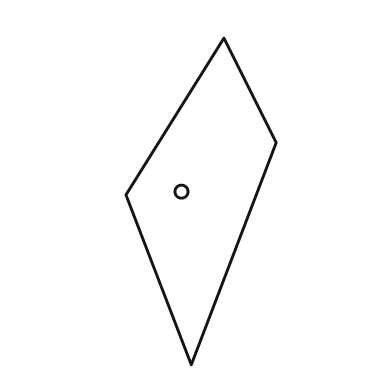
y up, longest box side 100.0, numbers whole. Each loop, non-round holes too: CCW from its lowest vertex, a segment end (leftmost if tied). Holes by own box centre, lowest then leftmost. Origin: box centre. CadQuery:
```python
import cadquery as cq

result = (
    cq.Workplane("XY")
    .moveTo(-3.0, -50.0)
    .lineTo(23.0, 18.0)
    .lineTo(7.0, 50.0)
    .lineTo(-23.0, 2.0)
    .close()
    .moveTo(-6.0, 3.0)
    .circle(2.0)
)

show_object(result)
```